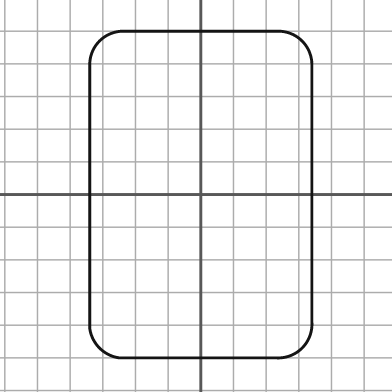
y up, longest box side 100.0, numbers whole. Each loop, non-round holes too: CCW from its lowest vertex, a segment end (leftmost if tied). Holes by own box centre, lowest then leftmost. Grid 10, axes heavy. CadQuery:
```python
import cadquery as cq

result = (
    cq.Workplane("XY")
    .moveTo(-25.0, -50.0)
    .lineTo(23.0, -50.0)
    .threePointArc((31.0, -47.0), (34.0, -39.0))
    .lineTo(34.0, 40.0)
    .threePointArc((31.0, 47.0), (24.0, 50.0))
    .lineTo(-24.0, 50.0)
    .threePointArc((-31.0, 47.0), (-34.0, 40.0))
    .lineTo(-34.0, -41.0)
    .threePointArc((-31.0, -47.0), (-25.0, -50.0))
    .close()
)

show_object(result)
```